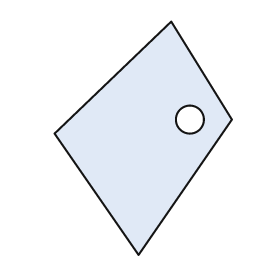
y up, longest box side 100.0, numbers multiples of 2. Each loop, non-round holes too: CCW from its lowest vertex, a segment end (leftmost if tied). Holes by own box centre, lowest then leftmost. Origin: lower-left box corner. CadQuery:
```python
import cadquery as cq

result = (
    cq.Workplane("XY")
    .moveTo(36.0, 0.0)
    .lineTo(76.0, 58.0)
    .lineTo(50.0, 100.0)
    .lineTo(0.0, 52.0)
    .close()
    .moveTo(58.0, 58.0)
    .circle(6.0)
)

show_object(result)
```